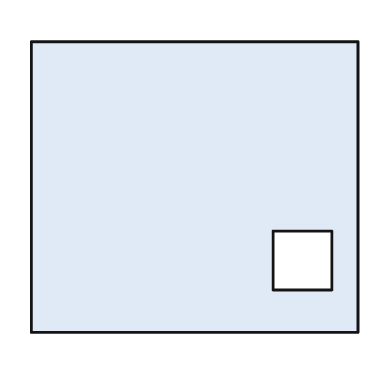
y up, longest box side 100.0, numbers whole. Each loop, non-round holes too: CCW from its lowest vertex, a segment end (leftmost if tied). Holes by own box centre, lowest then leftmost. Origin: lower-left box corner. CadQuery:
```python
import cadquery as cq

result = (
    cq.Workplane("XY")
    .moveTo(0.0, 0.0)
    .lineTo(100.0, 0.0)
    .lineTo(100.0, 89.0)
    .lineTo(0.0, 89.0)
    .close()
    .moveTo(74.0, 13.0)
    .lineTo(92.0, 13.0)
    .lineTo(92.0, 31.0)
    .lineTo(74.0, 31.0)
    .close()
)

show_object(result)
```